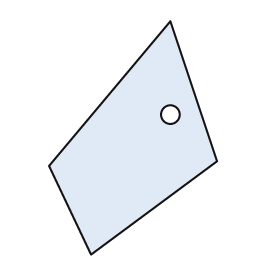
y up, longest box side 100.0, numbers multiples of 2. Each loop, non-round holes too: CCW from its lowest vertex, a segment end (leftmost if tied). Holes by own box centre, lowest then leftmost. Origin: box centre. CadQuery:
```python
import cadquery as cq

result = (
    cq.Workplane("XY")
    .moveTo(-18.0, -50.0)
    .lineTo(36.0, -10.0)
    .lineTo(16.0, 50.0)
    .lineTo(-36.0, -12.0)
    .close()
    .moveTo(16.0, 10.0)
    .circle(4.0)
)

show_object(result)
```